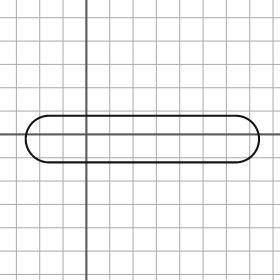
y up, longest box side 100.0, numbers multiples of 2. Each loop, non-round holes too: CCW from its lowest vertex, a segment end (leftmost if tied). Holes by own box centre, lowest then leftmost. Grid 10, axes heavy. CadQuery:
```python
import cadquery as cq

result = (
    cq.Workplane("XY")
    .moveTo(-16.0, -12.0)
    .lineTo(64.0, -12.0)
    .threePointArc((74.0, -2.0), (64.0, 8.0))
    .lineTo(-16.0, 8.0)
    .threePointArc((-26.0, -2.0), (-16.0, -12.0))
    .close()
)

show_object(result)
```